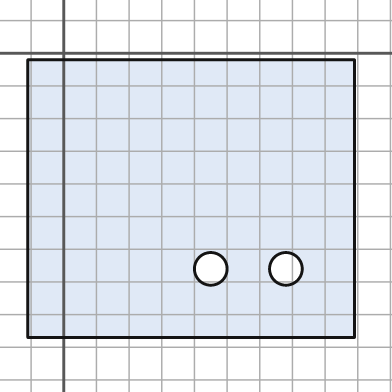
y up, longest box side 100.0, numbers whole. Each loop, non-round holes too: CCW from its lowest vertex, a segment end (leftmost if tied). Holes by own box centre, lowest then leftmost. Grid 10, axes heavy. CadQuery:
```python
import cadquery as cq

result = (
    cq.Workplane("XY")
    .moveTo(-11.0, -87.0)
    .lineTo(89.0, -87.0)
    .lineTo(89.0, -2.0)
    .lineTo(-11.0, -2.0)
    .close()
    .moveTo(45.0, -66.0)
    .circle(5.0)
    .moveTo(68.0, -66.0)
    .circle(5.0)
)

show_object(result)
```